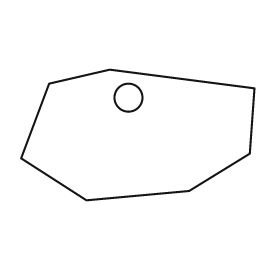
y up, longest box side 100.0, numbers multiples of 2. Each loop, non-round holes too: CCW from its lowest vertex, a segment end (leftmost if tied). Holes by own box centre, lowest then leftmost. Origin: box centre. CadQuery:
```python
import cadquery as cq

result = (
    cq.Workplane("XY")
    .moveTo(-22.0, -28.0)
    .lineTo(22.0, -24.0)
    .lineTo(48.0, -8.0)
    .lineTo(50.0, 20.0)
    .lineTo(-12.0, 28.0)
    .lineTo(-38.0, 22.0)
    .lineTo(-50.0, -10.0)
    .close()
    .moveTo(-4.0, 16.0)
    .circle(6.0)
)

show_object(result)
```